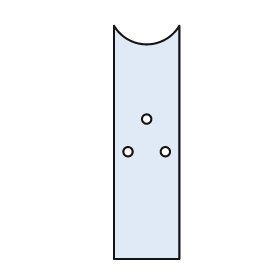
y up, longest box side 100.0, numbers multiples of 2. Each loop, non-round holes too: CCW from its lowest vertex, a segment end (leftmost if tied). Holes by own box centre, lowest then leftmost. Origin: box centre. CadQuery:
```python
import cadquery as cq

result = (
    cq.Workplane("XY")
    .moveTo(-14.0, -50.0)
    .lineTo(14.0, -50.0)
    .lineTo(14.0, 50.0)
    .threePointArc((0.0, 42.0), (-14.0, 50.0))
    .close()
    .moveTo(-8.0, -4.0)
    .circle(2.0)
    .moveTo(8.0, -4.0)
    .circle(2.0)
    .moveTo(0.0, 10.0)
    .circle(2.0)
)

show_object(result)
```